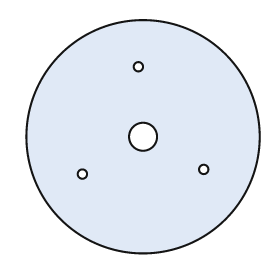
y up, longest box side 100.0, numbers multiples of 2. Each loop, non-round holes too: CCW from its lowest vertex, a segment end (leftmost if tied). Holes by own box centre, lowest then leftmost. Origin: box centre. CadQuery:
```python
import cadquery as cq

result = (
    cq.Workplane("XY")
    .moveTo(0.0, 0.0)
    .circle(50.0)
    .moveTo(-26.0, -16.0)
    .circle(2.0)
    .moveTo(26.0, -14.0)
    .circle(2.0)
    .moveTo(0.0, 0.0)
    .circle(6.0)
    .moveTo(-2.0, 30.0)
    .circle(2.0)
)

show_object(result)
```